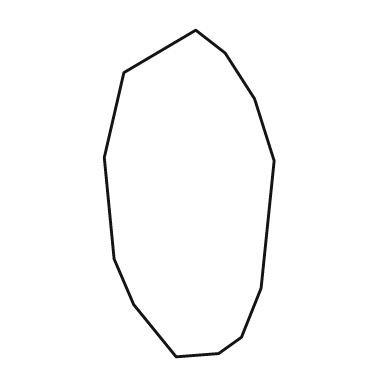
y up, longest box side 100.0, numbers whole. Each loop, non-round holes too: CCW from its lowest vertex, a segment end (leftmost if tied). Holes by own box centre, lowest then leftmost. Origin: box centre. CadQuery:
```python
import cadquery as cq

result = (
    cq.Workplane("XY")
    .moveTo(-4.0, -50.0)
    .lineTo(9.0, -49.0)
    .lineTo(16.0, -44.0)
    .lineTo(22.0, -29.0)
    .lineTo(26.0, 10.0)
    .lineTo(20.0, 29.0)
    .lineTo(11.0, 43.0)
    .lineTo(2.0, 50.0)
    .lineTo(-20.0, 37.0)
    .lineTo(-26.0, 11.0)
    .lineTo(-23.0, -20.0)
    .lineTo(-17.0, -34.0)
    .close()
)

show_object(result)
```